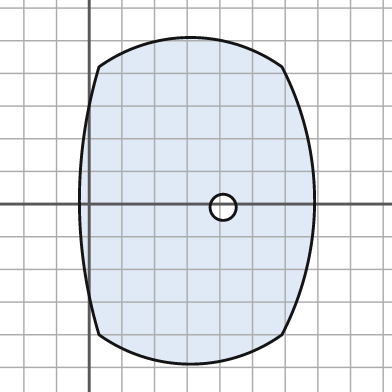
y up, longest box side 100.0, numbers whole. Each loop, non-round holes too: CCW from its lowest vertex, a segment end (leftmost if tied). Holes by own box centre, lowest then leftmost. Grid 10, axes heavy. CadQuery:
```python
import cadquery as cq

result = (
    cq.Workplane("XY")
    .moveTo(3.0, -40.0)
    .threePointArc((31.0, -49.0), (59.0, -40.0))
    .threePointArc((69.0, 1.0), (59.0, 42.0))
    .threePointArc((31.0, 51.0), (3.0, 42.0))
    .threePointArc((-3.0, 1.0), (3.0, -40.0))
    .close()
    .moveTo(41.0, -1.0)
    .circle(4.0)
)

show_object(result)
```